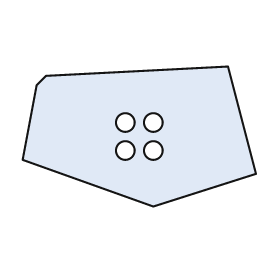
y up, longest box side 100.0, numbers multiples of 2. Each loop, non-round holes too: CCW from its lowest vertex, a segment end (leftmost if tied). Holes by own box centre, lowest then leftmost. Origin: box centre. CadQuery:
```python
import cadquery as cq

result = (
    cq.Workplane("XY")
    .moveTo(6.0, -30.0)
    .lineTo(50.0, -16.0)
    .lineTo(38.0, 30.0)
    .lineTo(-40.0, 26.0)
    .lineTo(-44.0, 22.0)
    .lineTo(-50.0, -10.0)
    .close()
    .moveTo(-6.0, -6.0)
    .circle(4.0)
    .moveTo(6.0, -6.0)
    .circle(4.0)
    .moveTo(-6.0, 6.0)
    .circle(4.0)
    .moveTo(6.0, 6.0)
    .circle(4.0)
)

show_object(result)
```